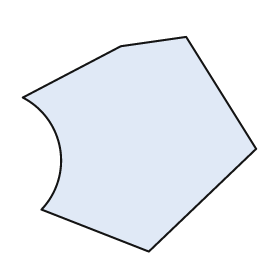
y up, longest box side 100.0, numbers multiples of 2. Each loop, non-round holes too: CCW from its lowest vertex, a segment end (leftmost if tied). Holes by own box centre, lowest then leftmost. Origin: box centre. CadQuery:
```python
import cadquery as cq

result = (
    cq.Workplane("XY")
    .moveTo(4.0, -46.0)
    .lineTo(50.0, -2.0)
    .lineTo(20.0, 46.0)
    .lineTo(-8.0, 42.0)
    .lineTo(-50.0, 20.0)
    .threePointArc((-34.0, -2.0), (-42.0, -28.0))
    .close()
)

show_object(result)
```